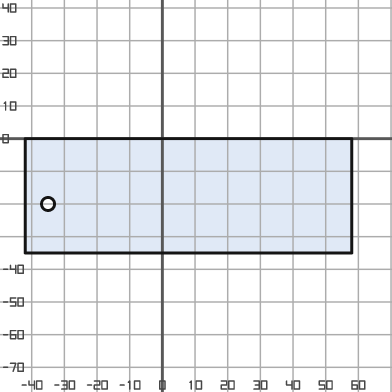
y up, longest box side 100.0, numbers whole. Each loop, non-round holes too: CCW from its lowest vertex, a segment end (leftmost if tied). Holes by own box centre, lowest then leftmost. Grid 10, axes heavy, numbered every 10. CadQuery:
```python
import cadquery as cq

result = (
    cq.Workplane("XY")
    .moveTo(-42.0, -35.0)
    .lineTo(58.0, -35.0)
    .lineTo(58.0, 0.0)
    .lineTo(-42.0, 0.0)
    .close()
    .moveTo(-35.0, -20.0)
    .circle(2.0)
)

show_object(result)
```